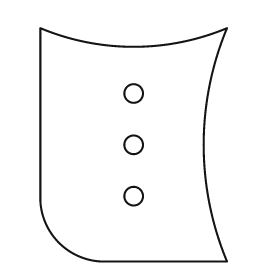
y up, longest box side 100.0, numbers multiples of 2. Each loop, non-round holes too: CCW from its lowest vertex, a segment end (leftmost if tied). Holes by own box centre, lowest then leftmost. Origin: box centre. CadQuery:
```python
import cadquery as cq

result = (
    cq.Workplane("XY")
    .moveTo(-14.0, -50.0)
    .lineTo(40.0, -50.0)
    .threePointArc((30.0, 0.0), (40.0, 50.0))
    .threePointArc((0.0, 42.0), (-40.0, 50.0))
    .lineTo(-40.0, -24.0)
    .threePointArc((-32.0, -42.0), (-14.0, -50.0))
    .close()
    .moveTo(0.0, -22.0)
    .circle(4.0)
    .moveTo(0.0, 0.0)
    .circle(4.0)
    .moveTo(0.0, 22.0)
    .circle(4.0)
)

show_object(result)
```